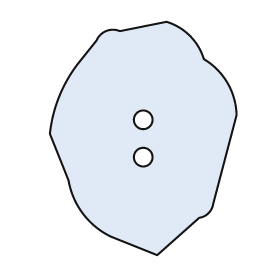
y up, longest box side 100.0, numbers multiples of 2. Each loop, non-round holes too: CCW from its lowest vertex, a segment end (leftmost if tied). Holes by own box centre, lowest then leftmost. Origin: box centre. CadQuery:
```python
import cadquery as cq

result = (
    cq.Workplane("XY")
    .moveTo(6.0, -50.0)
    .lineTo(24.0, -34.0)
    .threePointArc((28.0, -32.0), (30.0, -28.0))
    .lineTo(40.0, 10.0)
    .threePointArc((36.0, 24.0), (26.0, 34.0))
    .threePointArc((20.0, 44.0), (10.0, 50.0))
    .lineTo(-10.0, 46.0)
    .threePointArc((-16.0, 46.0), (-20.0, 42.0))
    .lineTo(-28.0, 32.0)
    .threePointArc((-36.0, 18.0), (-40.0, 2.0))
    .lineTo(-32.0, -18.0)
    .threePointArc((-26.0, -32.0), (-14.0, -42.0))
    .close()
    .moveTo(0.0, -8.0)
    .circle(4.0)
    .moveTo(0.0, 8.0)
    .circle(4.0)
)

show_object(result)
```